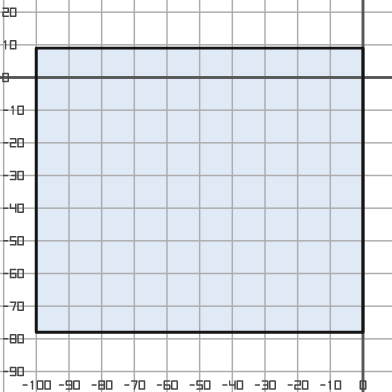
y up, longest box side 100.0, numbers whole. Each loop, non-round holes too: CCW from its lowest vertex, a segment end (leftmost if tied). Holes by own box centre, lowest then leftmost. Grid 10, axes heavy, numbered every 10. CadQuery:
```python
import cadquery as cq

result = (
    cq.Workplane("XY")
    .moveTo(-100.0, -78.0)
    .lineTo(0.0, -78.0)
    .lineTo(0.0, 9.0)
    .lineTo(-100.0, 9.0)
    .close()
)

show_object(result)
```